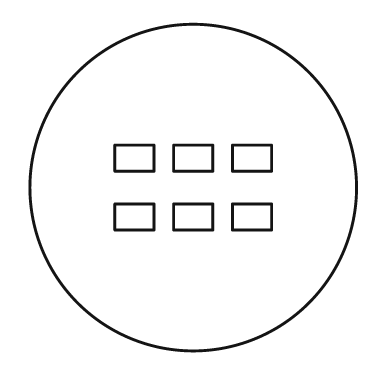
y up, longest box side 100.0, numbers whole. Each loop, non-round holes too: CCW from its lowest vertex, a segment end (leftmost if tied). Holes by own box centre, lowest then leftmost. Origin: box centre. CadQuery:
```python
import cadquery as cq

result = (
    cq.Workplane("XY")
    .moveTo(0.0, 0.0)
    .circle(50.0)
    .moveTo(-24.0, -13.0)
    .lineTo(-12.0, -13.0)
    .lineTo(-12.0, -5.0)
    .lineTo(-24.0, -5.0)
    .close()
    .moveTo(-6.0, -13.0)
    .lineTo(6.0, -13.0)
    .lineTo(6.0, -5.0)
    .lineTo(-6.0, -5.0)
    .close()
    .moveTo(12.0, -13.0)
    .lineTo(24.0, -13.0)
    .lineTo(24.0, -5.0)
    .lineTo(12.0, -5.0)
    .close()
    .moveTo(-24.0, 5.0)
    .lineTo(-12.0, 5.0)
    .lineTo(-12.0, 13.0)
    .lineTo(-24.0, 13.0)
    .close()
    .moveTo(-6.0, 5.0)
    .lineTo(6.0, 5.0)
    .lineTo(6.0, 13.0)
    .lineTo(-6.0, 13.0)
    .close()
    .moveTo(12.0, 5.0)
    .lineTo(24.0, 5.0)
    .lineTo(24.0, 13.0)
    .lineTo(12.0, 13.0)
    .close()
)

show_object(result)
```